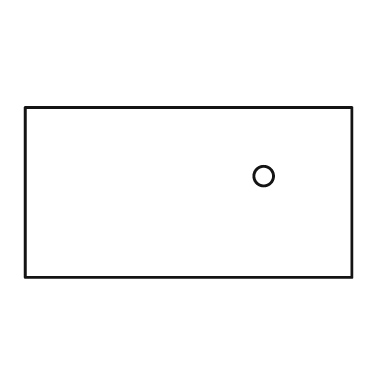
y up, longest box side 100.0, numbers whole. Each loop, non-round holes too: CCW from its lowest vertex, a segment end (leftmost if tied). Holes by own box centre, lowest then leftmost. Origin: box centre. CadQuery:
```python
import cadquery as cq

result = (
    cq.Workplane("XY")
    .moveTo(-50.0, -26.0)
    .lineTo(50.0, -26.0)
    .lineTo(50.0, 26.0)
    .lineTo(-50.0, 26.0)
    .close()
    .moveTo(23.0, 5.0)
    .circle(3.0)
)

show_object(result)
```